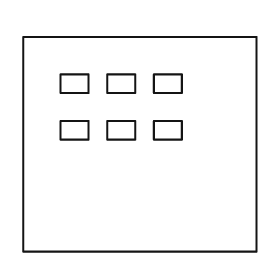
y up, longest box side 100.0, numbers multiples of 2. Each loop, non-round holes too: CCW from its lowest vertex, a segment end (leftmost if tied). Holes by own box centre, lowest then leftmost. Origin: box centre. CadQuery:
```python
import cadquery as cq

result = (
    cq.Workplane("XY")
    .moveTo(-50.0, -46.0)
    .lineTo(50.0, -46.0)
    .lineTo(50.0, 46.0)
    .lineTo(-50.0, 46.0)
    .close()
    .moveTo(-34.0, 2.0)
    .lineTo(-22.0, 2.0)
    .lineTo(-22.0, 10.0)
    .lineTo(-34.0, 10.0)
    .close()
    .moveTo(-14.0, 2.0)
    .lineTo(-2.0, 2.0)
    .lineTo(-2.0, 10.0)
    .lineTo(-14.0, 10.0)
    .close()
    .moveTo(6.0, 2.0)
    .lineTo(18.0, 2.0)
    .lineTo(18.0, 10.0)
    .lineTo(6.0, 10.0)
    .close()
    .moveTo(-34.0, 22.0)
    .lineTo(-22.0, 22.0)
    .lineTo(-22.0, 30.0)
    .lineTo(-34.0, 30.0)
    .close()
    .moveTo(-14.0, 22.0)
    .lineTo(-2.0, 22.0)
    .lineTo(-2.0, 30.0)
    .lineTo(-14.0, 30.0)
    .close()
    .moveTo(6.0, 22.0)
    .lineTo(18.0, 22.0)
    .lineTo(18.0, 30.0)
    .lineTo(6.0, 30.0)
    .close()
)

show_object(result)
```